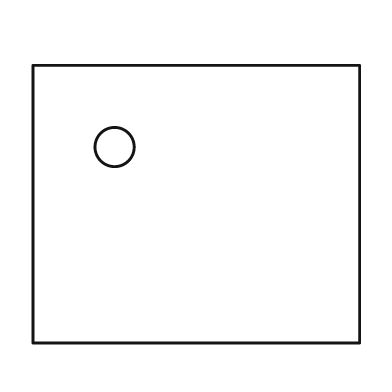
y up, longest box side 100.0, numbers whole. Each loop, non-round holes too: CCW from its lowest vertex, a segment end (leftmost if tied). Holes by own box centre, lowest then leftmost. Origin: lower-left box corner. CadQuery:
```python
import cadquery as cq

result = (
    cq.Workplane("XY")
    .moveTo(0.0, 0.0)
    .lineTo(100.0, 0.0)
    .lineTo(100.0, 85.0)
    .lineTo(0.0, 85.0)
    .close()
    .moveTo(25.0, 60.0)
    .circle(6.0)
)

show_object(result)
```